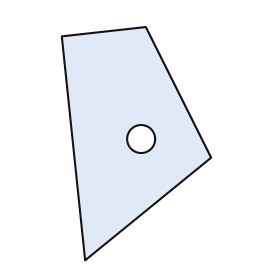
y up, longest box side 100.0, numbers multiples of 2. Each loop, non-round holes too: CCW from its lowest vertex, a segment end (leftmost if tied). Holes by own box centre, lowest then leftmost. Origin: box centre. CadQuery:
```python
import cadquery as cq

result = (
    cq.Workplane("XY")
    .moveTo(-22.0, -50.0)
    .lineTo(32.0, -6.0)
    .lineTo(4.0, 50.0)
    .lineTo(-32.0, 46.0)
    .close()
    .moveTo(2.0, 2.0)
    .circle(6.0)
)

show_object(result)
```